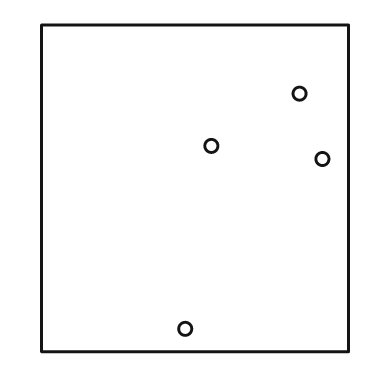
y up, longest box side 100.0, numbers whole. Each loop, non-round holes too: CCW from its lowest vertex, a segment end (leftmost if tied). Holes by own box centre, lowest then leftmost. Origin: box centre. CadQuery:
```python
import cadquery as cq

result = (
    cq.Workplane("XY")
    .moveTo(-47.0, -50.0)
    .lineTo(47.0, -50.0)
    .lineTo(47.0, 50.0)
    .lineTo(-47.0, 50.0)
    .close()
    .moveTo(-3.0, -43.0)
    .circle(2.0)
    .moveTo(39.0, 9.0)
    .circle(2.0)
    .moveTo(5.0, 13.0)
    .circle(2.0)
    .moveTo(32.0, 29.0)
    .circle(2.0)
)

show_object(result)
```